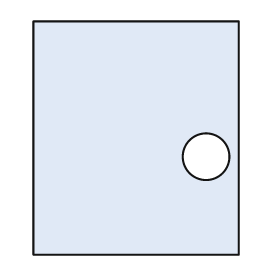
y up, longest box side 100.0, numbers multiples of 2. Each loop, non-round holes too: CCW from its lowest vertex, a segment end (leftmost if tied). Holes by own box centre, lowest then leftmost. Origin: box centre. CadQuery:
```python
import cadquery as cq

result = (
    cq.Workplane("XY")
    .moveTo(-44.0, -50.0)
    .lineTo(44.0, -50.0)
    .lineTo(44.0, 50.0)
    .lineTo(-44.0, 50.0)
    .close()
    .moveTo(30.0, -8.0)
    .circle(10.0)
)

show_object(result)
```